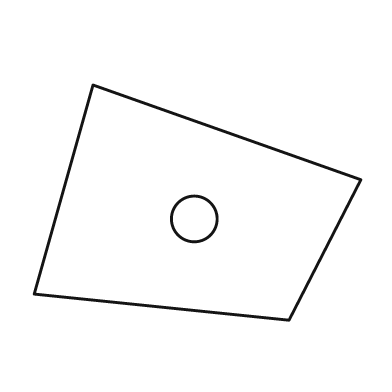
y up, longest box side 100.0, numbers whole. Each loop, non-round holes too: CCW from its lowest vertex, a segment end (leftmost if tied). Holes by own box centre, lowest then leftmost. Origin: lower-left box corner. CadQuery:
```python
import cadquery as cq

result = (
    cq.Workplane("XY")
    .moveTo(78.0, 0.0)
    .lineTo(100.0, 43.0)
    .lineTo(18.0, 72.0)
    .lineTo(0.0, 8.0)
    .close()
    .moveTo(49.0, 31.0)
    .circle(7.0)
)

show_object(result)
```